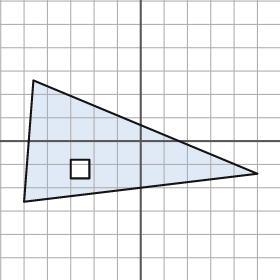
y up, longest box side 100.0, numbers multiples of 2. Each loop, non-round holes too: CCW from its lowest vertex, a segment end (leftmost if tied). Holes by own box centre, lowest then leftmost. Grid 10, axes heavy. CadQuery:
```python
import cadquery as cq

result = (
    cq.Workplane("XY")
    .moveTo(-50.0, -26.0)
    .lineTo(50.0, -14.0)
    .lineTo(-46.0, 26.0)
    .close()
    .moveTo(-30.0, -16.0)
    .lineTo(-22.0, -16.0)
    .lineTo(-22.0, -8.0)
    .lineTo(-30.0, -8.0)
    .close()
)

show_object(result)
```